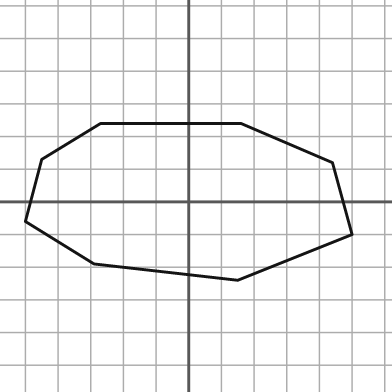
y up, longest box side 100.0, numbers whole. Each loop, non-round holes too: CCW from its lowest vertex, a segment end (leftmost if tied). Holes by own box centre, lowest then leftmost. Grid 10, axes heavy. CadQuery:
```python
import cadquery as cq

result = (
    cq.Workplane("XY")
    .moveTo(15.0, -24.0)
    .lineTo(50.0, -10.0)
    .lineTo(44.0, 12.0)
    .lineTo(16.0, 24.0)
    .lineTo(-27.0, 24.0)
    .lineTo(-45.0, 13.0)
    .lineTo(-50.0, -6.0)
    .lineTo(-29.0, -19.0)
    .close()
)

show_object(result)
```